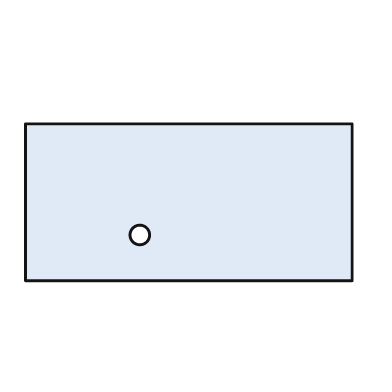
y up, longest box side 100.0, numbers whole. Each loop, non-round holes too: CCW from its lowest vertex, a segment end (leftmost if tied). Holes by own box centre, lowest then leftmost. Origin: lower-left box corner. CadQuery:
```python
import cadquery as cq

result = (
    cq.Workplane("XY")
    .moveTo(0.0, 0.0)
    .lineTo(100.0, 0.0)
    .lineTo(100.0, 48.0)
    .lineTo(0.0, 48.0)
    .close()
    .moveTo(35.0, 14.0)
    .circle(3.0)
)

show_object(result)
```